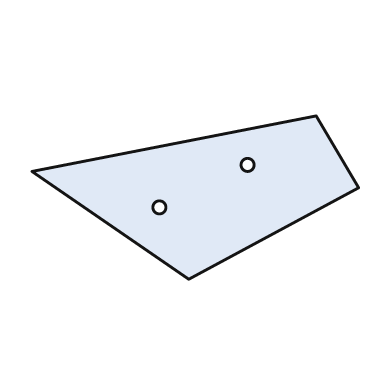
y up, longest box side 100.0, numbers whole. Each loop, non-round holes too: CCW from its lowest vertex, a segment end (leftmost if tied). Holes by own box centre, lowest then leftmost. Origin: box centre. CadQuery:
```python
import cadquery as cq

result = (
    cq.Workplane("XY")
    .moveTo(-2.0, -25.0)
    .lineTo(50.0, 3.0)
    .lineTo(37.0, 25.0)
    .lineTo(-50.0, 8.0)
    .close()
    .moveTo(-11.0, -3.0)
    .circle(2.0)
    .moveTo(16.0, 10.0)
    .circle(2.0)
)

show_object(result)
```